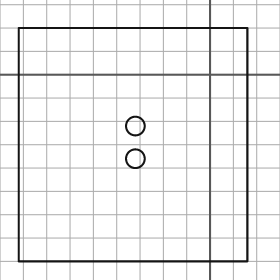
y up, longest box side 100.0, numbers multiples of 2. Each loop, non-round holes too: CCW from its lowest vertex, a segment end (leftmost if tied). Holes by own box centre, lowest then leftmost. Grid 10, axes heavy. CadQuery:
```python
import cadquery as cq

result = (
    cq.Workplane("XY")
    .moveTo(-82.0, -80.0)
    .lineTo(16.0, -80.0)
    .lineTo(16.0, 20.0)
    .lineTo(-82.0, 20.0)
    .close()
    .moveTo(-32.0, -36.0)
    .circle(4.0)
    .moveTo(-32.0, -22.0)
    .circle(4.0)
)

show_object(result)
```